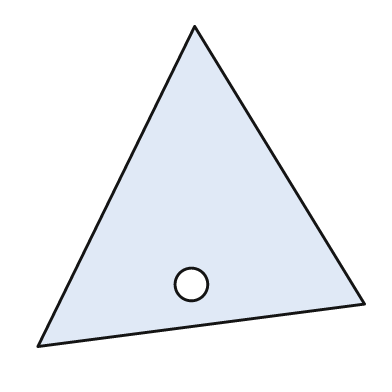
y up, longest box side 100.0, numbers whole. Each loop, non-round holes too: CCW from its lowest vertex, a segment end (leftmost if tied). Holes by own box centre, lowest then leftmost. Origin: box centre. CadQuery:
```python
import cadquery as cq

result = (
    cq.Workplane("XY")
    .moveTo(-50.0, -49.0)
    .lineTo(50.0, -36.0)
    .lineTo(-2.0, 49.0)
    .close()
    .moveTo(-3.0, -30.0)
    .circle(5.0)
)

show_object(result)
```